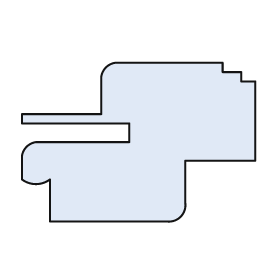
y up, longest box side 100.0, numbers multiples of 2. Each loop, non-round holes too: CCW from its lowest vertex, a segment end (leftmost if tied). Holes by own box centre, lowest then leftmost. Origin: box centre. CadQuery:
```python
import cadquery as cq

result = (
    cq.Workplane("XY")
    .moveTo(-38.0, -34.0)
    .lineTo(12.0, -34.0)
    .threePointArc((18.0, -32.0), (20.0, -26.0))
    .lineTo(20.0, -8.0)
    .lineTo(50.0, -8.0)
    .lineTo(50.0, 26.0)
    .lineTo(44.0, 26.0)
    .lineTo(44.0, 30.0)
    .lineTo(36.0, 30.0)
    .lineTo(36.0, 34.0)
    .lineTo(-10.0, 34.0)
    .threePointArc((-14.0, 32.0), (-16.0, 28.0))
    .lineTo(-16.0, 12.0)
    .lineTo(-50.0, 12.0)
    .lineTo(-50.0, 8.0)
    .lineTo(-4.0, 8.0)
    .lineTo(-4.0, 0.0)
    .lineTo(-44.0, 0.0)
    .threePointArc((-48.0, -2.0), (-50.0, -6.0))
    .lineTo(-50.0, -16.0)
    .threePointArc((-44.0, -18.0), (-38.0, -16.0))
    .close()
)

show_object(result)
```